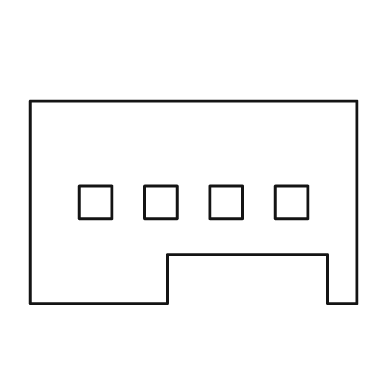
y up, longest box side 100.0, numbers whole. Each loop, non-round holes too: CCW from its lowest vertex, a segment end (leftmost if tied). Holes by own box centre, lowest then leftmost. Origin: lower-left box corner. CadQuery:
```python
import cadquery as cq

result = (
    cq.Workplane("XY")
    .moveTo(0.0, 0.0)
    .lineTo(42.0, 0.0)
    .lineTo(42.0, 15.0)
    .lineTo(91.0, 15.0)
    .lineTo(91.0, 0.0)
    .lineTo(100.0, 0.0)
    .lineTo(100.0, 62.0)
    .lineTo(0.0, 62.0)
    .close()
    .moveTo(15.0, 26.0)
    .lineTo(25.0, 26.0)
    .lineTo(25.0, 36.0)
    .lineTo(15.0, 36.0)
    .close()
    .moveTo(35.0, 26.0)
    .lineTo(45.0, 26.0)
    .lineTo(45.0, 36.0)
    .lineTo(35.0, 36.0)
    .close()
    .moveTo(55.0, 26.0)
    .lineTo(65.0, 26.0)
    .lineTo(65.0, 36.0)
    .lineTo(55.0, 36.0)
    .close()
    .moveTo(75.0, 26.0)
    .lineTo(85.0, 26.0)
    .lineTo(85.0, 36.0)
    .lineTo(75.0, 36.0)
    .close()
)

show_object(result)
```